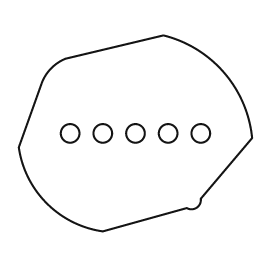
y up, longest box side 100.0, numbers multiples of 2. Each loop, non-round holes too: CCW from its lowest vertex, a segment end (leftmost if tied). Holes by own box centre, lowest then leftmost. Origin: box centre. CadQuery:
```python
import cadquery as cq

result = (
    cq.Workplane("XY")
    .moveTo(-14.0, -42.0)
    .lineTo(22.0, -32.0)
    .threePointArc((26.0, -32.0), (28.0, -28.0))
    .lineTo(50.0, -2.0)
    .threePointArc((38.0, 26.0), (12.0, 42.0))
    .lineTo(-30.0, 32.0)
    .threePointArc((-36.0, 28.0), (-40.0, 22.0))
    .lineTo(-50.0, -6.0)
    .threePointArc((-38.0, -30.0), (-14.0, -42.0))
    .close()
    .moveTo(-28.0, 0.0)
    .circle(4.0)
    .moveTo(-14.0, 0.0)
    .circle(4.0)
    .moveTo(0.0, 0.0)
    .circle(4.0)
    .moveTo(14.0, 0.0)
    .circle(4.0)
    .moveTo(28.0, 0.0)
    .circle(4.0)
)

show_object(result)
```